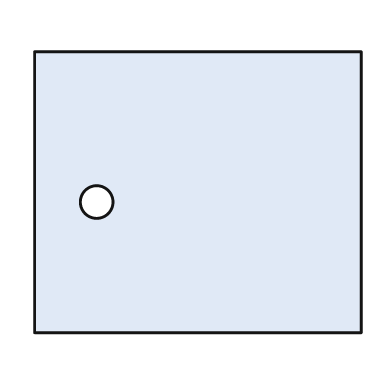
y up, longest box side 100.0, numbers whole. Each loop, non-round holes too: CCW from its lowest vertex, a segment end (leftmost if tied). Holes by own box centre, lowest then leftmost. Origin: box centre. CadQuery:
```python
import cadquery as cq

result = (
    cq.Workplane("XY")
    .moveTo(-50.0, -43.0)
    .lineTo(50.0, -43.0)
    .lineTo(50.0, 43.0)
    .lineTo(-50.0, 43.0)
    .close()
    .moveTo(-31.0, -3.0)
    .circle(5.0)
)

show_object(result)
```